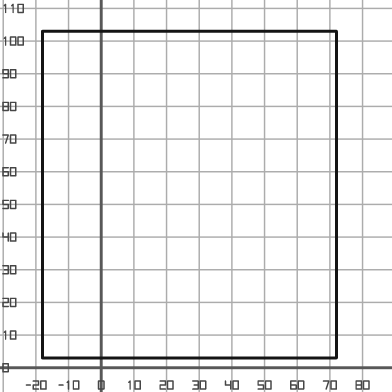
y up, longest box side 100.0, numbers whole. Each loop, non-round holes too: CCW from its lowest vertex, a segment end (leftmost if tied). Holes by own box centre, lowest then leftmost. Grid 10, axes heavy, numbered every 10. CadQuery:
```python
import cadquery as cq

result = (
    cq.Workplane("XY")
    .moveTo(-18.0, 3.0)
    .lineTo(72.0, 3.0)
    .lineTo(72.0, 103.0)
    .lineTo(-18.0, 103.0)
    .close()
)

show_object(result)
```